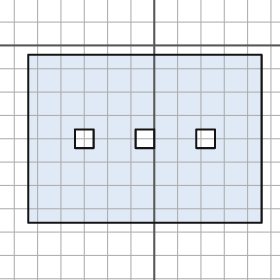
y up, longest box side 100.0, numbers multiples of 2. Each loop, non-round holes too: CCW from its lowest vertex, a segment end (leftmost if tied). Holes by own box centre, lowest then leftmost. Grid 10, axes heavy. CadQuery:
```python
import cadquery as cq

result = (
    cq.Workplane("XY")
    .moveTo(-54.0, -76.0)
    .lineTo(46.0, -76.0)
    .lineTo(46.0, -4.0)
    .lineTo(-54.0, -4.0)
    .close()
    .moveTo(-34.0, -44.0)
    .lineTo(-26.0, -44.0)
    .lineTo(-26.0, -36.0)
    .lineTo(-34.0, -36.0)
    .close()
    .moveTo(-8.0, -44.0)
    .lineTo(0.0, -44.0)
    .lineTo(0.0, -36.0)
    .lineTo(-8.0, -36.0)
    .close()
    .moveTo(18.0, -44.0)
    .lineTo(26.0, -44.0)
    .lineTo(26.0, -36.0)
    .lineTo(18.0, -36.0)
    .close()
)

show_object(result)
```